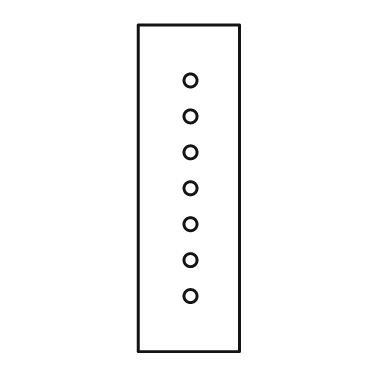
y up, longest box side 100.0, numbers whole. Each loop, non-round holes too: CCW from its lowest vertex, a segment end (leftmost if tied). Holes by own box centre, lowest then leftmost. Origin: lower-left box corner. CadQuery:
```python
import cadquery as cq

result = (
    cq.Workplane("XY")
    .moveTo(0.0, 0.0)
    .lineTo(31.0, 0.0)
    .lineTo(31.0, 100.0)
    .lineTo(0.0, 100.0)
    .close()
    .moveTo(16.0, 17.0)
    .circle(2.0)
    .moveTo(16.0, 28.0)
    .circle(2.0)
    .moveTo(16.0, 39.0)
    .circle(2.0)
    .moveTo(16.0, 50.0)
    .circle(2.0)
    .moveTo(16.0, 61.0)
    .circle(2.0)
    .moveTo(16.0, 72.0)
    .circle(2.0)
    .moveTo(16.0, 83.0)
    .circle(2.0)
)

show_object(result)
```